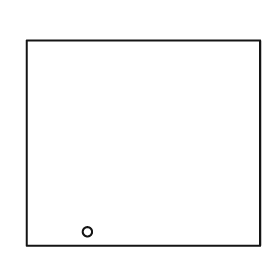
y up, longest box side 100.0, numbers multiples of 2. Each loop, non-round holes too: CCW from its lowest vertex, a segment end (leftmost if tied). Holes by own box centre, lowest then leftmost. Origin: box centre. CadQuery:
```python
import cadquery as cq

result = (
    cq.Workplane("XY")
    .moveTo(-50.0, -44.0)
    .lineTo(50.0, -44.0)
    .lineTo(50.0, 44.0)
    .lineTo(-50.0, 44.0)
    .close()
    .moveTo(-24.0, -38.0)
    .circle(2.0)
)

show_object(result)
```